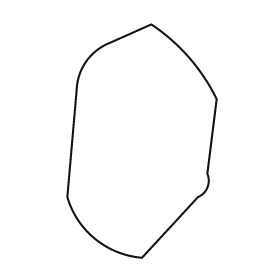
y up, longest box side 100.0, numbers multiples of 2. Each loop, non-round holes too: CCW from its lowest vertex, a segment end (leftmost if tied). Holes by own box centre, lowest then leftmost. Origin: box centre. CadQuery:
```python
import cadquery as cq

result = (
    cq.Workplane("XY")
    .moveTo(0.0, -50.0)
    .lineTo(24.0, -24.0)
    .threePointArc((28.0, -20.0), (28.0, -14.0))
    .lineTo(32.0, 18.0)
    .threePointArc((20.0, 36.0), (4.0, 50.0))
    .lineTo(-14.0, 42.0)
    .threePointArc((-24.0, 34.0), (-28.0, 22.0))
    .lineTo(-32.0, -24.0)
    .threePointArc((-20.0, -42.0), (0.0, -50.0))
    .close()
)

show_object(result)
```